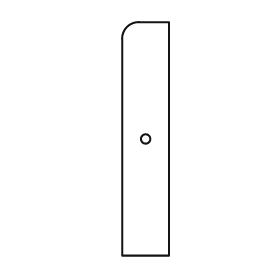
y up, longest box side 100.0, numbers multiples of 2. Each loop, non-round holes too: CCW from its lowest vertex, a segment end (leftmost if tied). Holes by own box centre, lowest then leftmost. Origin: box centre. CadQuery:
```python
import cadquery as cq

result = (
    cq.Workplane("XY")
    .moveTo(-10.0, -50.0)
    .lineTo(10.0, -50.0)
    .lineTo(10.0, 50.0)
    .lineTo(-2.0, 50.0)
    .threePointArc((-8.0, 48.0), (-10.0, 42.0))
    .close()
    .moveTo(0.0, 0.0)
    .circle(2.0)
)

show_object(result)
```